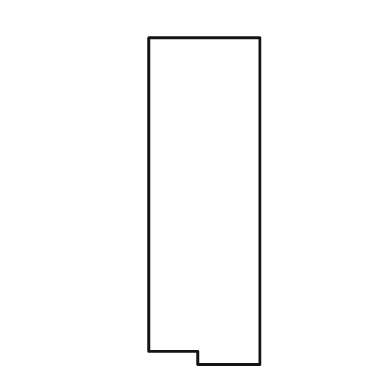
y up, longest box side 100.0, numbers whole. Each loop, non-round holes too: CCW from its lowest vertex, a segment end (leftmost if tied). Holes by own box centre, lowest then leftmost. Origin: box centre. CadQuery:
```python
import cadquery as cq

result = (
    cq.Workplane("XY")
    .moveTo(-2.0, -50.0)
    .lineTo(17.0, -50.0)
    .lineTo(17.0, 50.0)
    .lineTo(-17.0, 50.0)
    .lineTo(-17.0, -46.0)
    .lineTo(-2.0, -46.0)
    .close()
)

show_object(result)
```